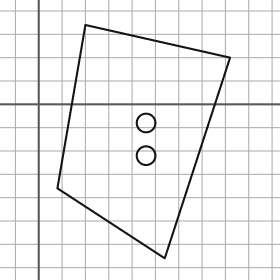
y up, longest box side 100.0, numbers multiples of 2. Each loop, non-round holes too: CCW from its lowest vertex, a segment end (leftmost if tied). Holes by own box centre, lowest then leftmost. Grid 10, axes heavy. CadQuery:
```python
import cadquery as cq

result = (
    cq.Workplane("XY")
    .moveTo(54.0, -66.0)
    .lineTo(82.0, 20.0)
    .lineTo(20.0, 34.0)
    .lineTo(8.0, -36.0)
    .close()
    .moveTo(46.0, -22.0)
    .circle(4.0)
    .moveTo(46.0, -8.0)
    .circle(4.0)
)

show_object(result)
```